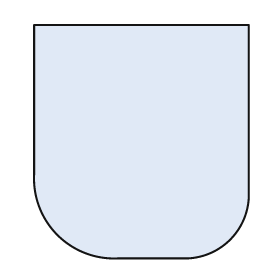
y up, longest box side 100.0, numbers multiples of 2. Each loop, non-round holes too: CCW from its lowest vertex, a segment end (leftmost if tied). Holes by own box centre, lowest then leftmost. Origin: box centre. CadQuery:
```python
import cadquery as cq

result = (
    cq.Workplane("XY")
    .moveTo(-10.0, -50.0)
    .lineTo(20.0, -50.0)
    .threePointArc((38.0, -42.0), (46.0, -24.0))
    .lineTo(46.0, 50.0)
    .lineTo(-46.0, 50.0)
    .lineTo(-46.0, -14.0)
    .threePointArc((-36.0, -40.0), (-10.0, -50.0))
    .close()
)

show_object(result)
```